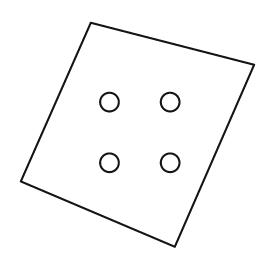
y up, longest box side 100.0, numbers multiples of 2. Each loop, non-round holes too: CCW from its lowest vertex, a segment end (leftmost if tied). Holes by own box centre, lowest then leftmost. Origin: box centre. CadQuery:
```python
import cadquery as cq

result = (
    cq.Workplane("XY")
    .moveTo(16.0, -48.0)
    .lineTo(50.0, 30.0)
    .lineTo(-20.0, 48.0)
    .lineTo(-50.0, -20.0)
    .close()
    .moveTo(-12.0, -12.0)
    .circle(4.0)
    .moveTo(14.0, -12.0)
    .circle(4.0)
    .moveTo(-12.0, 14.0)
    .circle(4.0)
    .moveTo(14.0, 14.0)
    .circle(4.0)
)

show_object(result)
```